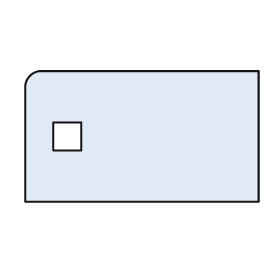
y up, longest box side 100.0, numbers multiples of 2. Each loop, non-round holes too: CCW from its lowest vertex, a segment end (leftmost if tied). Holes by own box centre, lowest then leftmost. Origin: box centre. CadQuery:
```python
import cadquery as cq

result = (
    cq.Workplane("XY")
    .moveTo(-50.0, -28.0)
    .lineTo(50.0, -28.0)
    .lineTo(50.0, 28.0)
    .lineTo(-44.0, 28.0)
    .threePointArc((-48.0, 26.0), (-50.0, 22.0))
    .close()
    .moveTo(-38.0, -6.0)
    .lineTo(-26.0, -6.0)
    .lineTo(-26.0, 6.0)
    .lineTo(-38.0, 6.0)
    .close()
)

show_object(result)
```